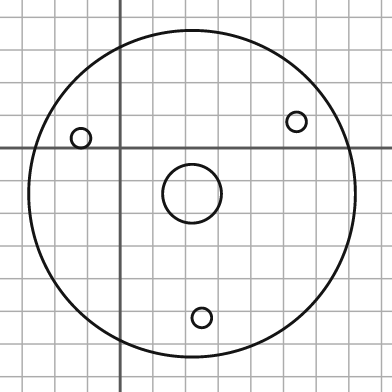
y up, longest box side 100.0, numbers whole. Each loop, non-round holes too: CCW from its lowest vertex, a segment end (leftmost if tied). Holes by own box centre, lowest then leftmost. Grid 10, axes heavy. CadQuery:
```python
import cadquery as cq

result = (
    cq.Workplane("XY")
    .moveTo(22.0, -14.0)
    .circle(50.0)
    .moveTo(25.0, -52.0)
    .circle(3.0)
    .moveTo(22.0, -14.0)
    .circle(9.0)
    .moveTo(-12.0, 3.0)
    .circle(3.0)
    .moveTo(54.0, 8.0)
    .circle(3.0)
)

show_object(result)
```